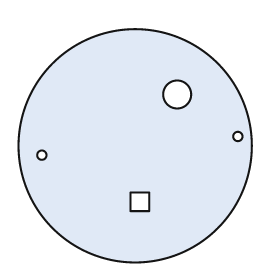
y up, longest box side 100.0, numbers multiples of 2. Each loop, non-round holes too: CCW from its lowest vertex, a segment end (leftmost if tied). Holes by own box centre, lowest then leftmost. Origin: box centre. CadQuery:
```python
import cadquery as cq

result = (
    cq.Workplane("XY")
    .moveTo(0.0, 0.0)
    .circle(50.0)
    .moveTo(-2.0, -28.0)
    .lineTo(6.0, -28.0)
    .lineTo(6.0, -20.0)
    .lineTo(-2.0, -20.0)
    .close()
    .moveTo(-40.0, -4.0)
    .circle(2.0)
    .moveTo(44.0, 4.0)
    .circle(2.0)
    .moveTo(18.0, 22.0)
    .circle(6.0)
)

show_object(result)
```